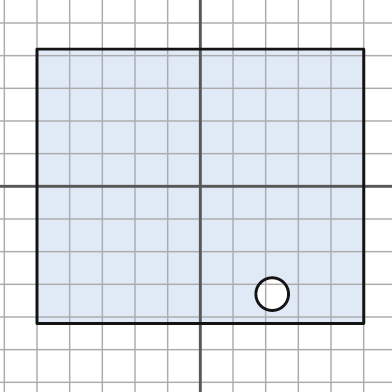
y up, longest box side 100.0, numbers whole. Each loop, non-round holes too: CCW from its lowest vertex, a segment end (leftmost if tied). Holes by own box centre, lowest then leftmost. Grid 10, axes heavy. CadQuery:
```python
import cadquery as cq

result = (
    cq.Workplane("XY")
    .moveTo(-50.0, -42.0)
    .lineTo(50.0, -42.0)
    .lineTo(50.0, 42.0)
    .lineTo(-50.0, 42.0)
    .close()
    .moveTo(22.0, -33.0)
    .circle(5.0)
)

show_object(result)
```